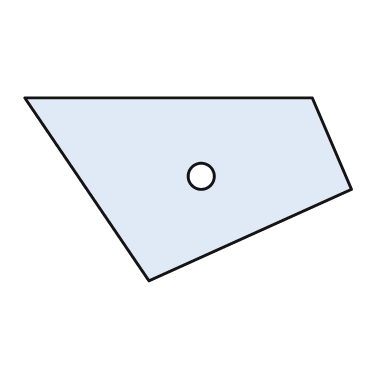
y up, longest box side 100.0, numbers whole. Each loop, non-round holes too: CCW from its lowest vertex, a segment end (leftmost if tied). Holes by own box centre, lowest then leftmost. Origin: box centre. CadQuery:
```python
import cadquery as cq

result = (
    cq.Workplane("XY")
    .moveTo(-12.0, -28.0)
    .lineTo(50.0, 0.0)
    .lineTo(38.0, 28.0)
    .lineTo(-50.0, 28.0)
    .close()
    .moveTo(4.0, 4.0)
    .circle(4.0)
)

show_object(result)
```